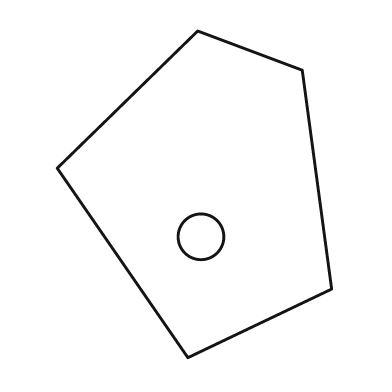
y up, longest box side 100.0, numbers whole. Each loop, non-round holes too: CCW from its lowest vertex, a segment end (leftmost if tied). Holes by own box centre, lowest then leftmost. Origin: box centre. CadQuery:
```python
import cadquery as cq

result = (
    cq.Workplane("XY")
    .moveTo(-2.0, -50.0)
    .lineTo(42.0, -29.0)
    .lineTo(33.0, 38.0)
    .lineTo(1.0, 50.0)
    .lineTo(-42.0, 8.0)
    .close()
    .moveTo(2.0, -13.0)
    .circle(7.0)
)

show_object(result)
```